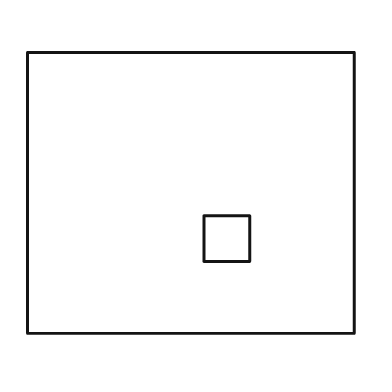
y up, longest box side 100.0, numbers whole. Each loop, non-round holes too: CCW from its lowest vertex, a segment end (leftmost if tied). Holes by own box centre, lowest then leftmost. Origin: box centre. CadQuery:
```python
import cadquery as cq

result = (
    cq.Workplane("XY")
    .moveTo(-50.0, -43.0)
    .lineTo(50.0, -43.0)
    .lineTo(50.0, 43.0)
    .lineTo(-50.0, 43.0)
    .close()
    .moveTo(4.0, -21.0)
    .lineTo(18.0, -21.0)
    .lineTo(18.0, -7.0)
    .lineTo(4.0, -7.0)
    .close()
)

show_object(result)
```